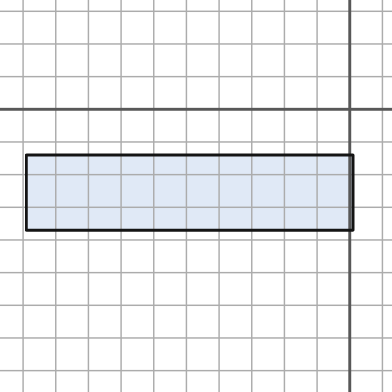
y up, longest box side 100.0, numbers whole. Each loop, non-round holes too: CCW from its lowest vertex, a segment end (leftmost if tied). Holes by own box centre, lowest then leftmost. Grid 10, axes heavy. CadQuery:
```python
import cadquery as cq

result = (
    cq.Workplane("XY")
    .moveTo(-99.0, -37.0)
    .lineTo(1.0, -37.0)
    .lineTo(1.0, -14.0)
    .lineTo(-99.0, -14.0)
    .close()
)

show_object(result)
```